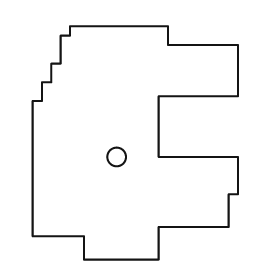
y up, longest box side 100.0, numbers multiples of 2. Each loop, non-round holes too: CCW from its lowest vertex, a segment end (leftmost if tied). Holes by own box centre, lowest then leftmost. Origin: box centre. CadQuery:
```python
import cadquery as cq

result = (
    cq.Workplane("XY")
    .moveTo(-22.0, -50.0)
    .lineTo(10.0, -50.0)
    .lineTo(10.0, -36.0)
    .lineTo(40.0, -36.0)
    .lineTo(40.0, -22.0)
    .lineTo(44.0, -22.0)
    .lineTo(44.0, -6.0)
    .lineTo(10.0, -6.0)
    .lineTo(10.0, 20.0)
    .lineTo(44.0, 20.0)
    .lineTo(44.0, 42.0)
    .lineTo(14.0, 42.0)
    .lineTo(14.0, 50.0)
    .lineTo(-28.0, 50.0)
    .lineTo(-28.0, 46.0)
    .lineTo(-32.0, 46.0)
    .lineTo(-32.0, 34.0)
    .lineTo(-36.0, 34.0)
    .lineTo(-36.0, 26.0)
    .lineTo(-40.0, 26.0)
    .lineTo(-40.0, 18.0)
    .lineTo(-44.0, 18.0)
    .lineTo(-44.0, -40.0)
    .lineTo(-22.0, -40.0)
    .close()
    .moveTo(-8.0, -6.0)
    .circle(4.0)
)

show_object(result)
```